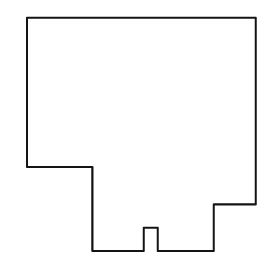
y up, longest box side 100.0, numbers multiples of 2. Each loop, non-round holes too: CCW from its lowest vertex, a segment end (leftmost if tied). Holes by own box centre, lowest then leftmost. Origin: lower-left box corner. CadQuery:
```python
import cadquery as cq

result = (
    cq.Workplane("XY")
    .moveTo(28.0, 0.0)
    .lineTo(50.0, 0.0)
    .lineTo(50.0, 10.0)
    .lineTo(56.0, 10.0)
    .lineTo(56.0, 0.0)
    .lineTo(80.0, 0.0)
    .lineTo(80.0, 20.0)
    .lineTo(98.0, 20.0)
    .lineTo(98.0, 100.0)
    .lineTo(0.0, 100.0)
    .lineTo(0.0, 36.0)
    .lineTo(28.0, 36.0)
    .close()
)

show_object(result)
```